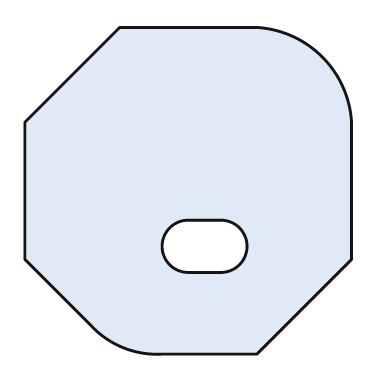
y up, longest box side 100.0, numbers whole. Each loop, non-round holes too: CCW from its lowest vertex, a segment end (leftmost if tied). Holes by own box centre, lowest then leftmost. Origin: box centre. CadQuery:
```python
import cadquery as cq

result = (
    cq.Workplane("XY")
    .moveTo(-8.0, -50.0)
    .lineTo(21.0, -50.0)
    .lineTo(50.0, -21.0)
    .lineTo(50.0, 21.0)
    .threePointArc((41.0, 41.0), (21.0, 50.0))
    .lineTo(-21.0, 50.0)
    .lineTo(-50.0, 21.0)
    .lineTo(-50.0, -21.0)
    .lineTo(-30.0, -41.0)
    .threePointArc((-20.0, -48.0), (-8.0, -50.0))
    .close()
    .moveTo(0.0, -25.0)
    .lineTo(10.0, -25.0)
    .threePointArc((18.0, -17.0), (10.0, -9.0))
    .lineTo(0.0, -9.0)
    .threePointArc((-8.0, -17.0), (0.0, -25.0))
    .close()
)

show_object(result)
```